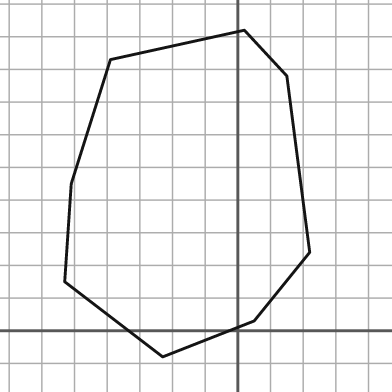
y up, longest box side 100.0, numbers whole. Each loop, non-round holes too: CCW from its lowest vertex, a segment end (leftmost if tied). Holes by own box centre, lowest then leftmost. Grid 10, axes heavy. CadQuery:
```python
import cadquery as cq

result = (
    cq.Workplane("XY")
    .moveTo(-23.0, -8.0)
    .lineTo(5.0, 3.0)
    .lineTo(22.0, 24.0)
    .lineTo(15.0, 78.0)
    .lineTo(2.0, 92.0)
    .lineTo(-39.0, 83.0)
    .lineTo(-51.0, 45.0)
    .lineTo(-53.0, 15.0)
    .close()
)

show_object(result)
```